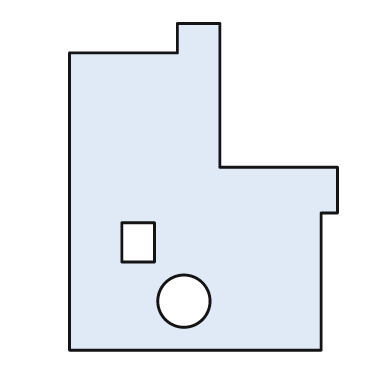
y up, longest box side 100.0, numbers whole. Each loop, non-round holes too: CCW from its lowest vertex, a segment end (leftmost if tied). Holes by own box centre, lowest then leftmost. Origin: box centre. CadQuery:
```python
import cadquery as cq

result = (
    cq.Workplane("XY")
    .moveTo(-41.0, -50.0)
    .lineTo(36.0, -50.0)
    .lineTo(36.0, -8.0)
    .lineTo(41.0, -8.0)
    .lineTo(41.0, 6.0)
    .lineTo(5.0, 6.0)
    .lineTo(5.0, 50.0)
    .lineTo(-8.0, 50.0)
    .lineTo(-8.0, 41.0)
    .lineTo(-41.0, 41.0)
    .close()
    .moveTo(-6.0, -35.0)
    .circle(8.0)
    .moveTo(-25.0, -23.0)
    .lineTo(-15.0, -23.0)
    .lineTo(-15.0, -11.0)
    .lineTo(-25.0, -11.0)
    .close()
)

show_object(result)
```